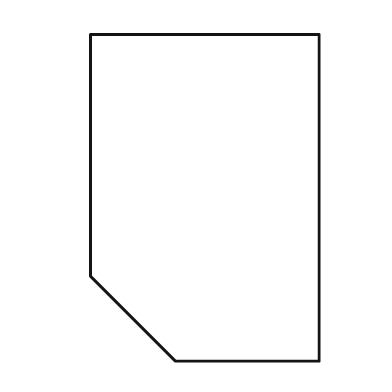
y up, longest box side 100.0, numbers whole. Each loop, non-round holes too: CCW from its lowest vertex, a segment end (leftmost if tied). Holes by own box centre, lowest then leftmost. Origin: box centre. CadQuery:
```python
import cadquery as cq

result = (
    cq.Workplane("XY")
    .moveTo(-9.0, -50.0)
    .lineTo(35.0, -50.0)
    .lineTo(35.0, 50.0)
    .lineTo(-35.0, 50.0)
    .lineTo(-35.0, -24.0)
    .close()
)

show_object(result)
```